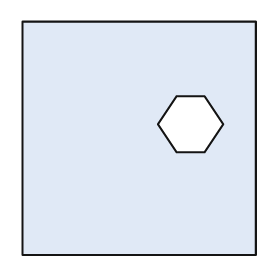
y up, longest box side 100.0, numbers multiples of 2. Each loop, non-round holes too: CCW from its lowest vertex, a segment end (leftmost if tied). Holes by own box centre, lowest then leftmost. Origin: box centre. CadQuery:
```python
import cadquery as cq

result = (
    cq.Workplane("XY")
    .moveTo(-50.0, -50.0)
    .lineTo(50.0, -50.0)
    .lineTo(50.0, 50.0)
    .lineTo(-50.0, 50.0)
    .close()
    .moveTo(16.0, -6.0)
    .lineTo(28.0, -6.0)
    .lineTo(36.0, 6.0)
    .lineTo(28.0, 18.0)
    .lineTo(16.0, 18.0)
    .lineTo(8.0, 6.0)
    .close()
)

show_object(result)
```